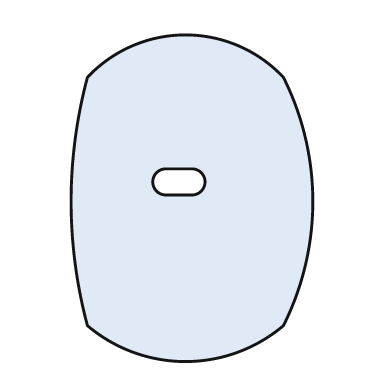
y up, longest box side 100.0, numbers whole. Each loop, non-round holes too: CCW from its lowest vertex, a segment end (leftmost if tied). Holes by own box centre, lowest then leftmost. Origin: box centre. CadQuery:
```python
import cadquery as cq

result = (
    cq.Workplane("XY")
    .moveTo(-32.0, -39.0)
    .threePointArc((-2.0, -50.0), (28.0, -39.0))
    .threePointArc((37.0, -1.0), (28.0, 37.0))
    .threePointArc((-2.0, 50.0), (-32.0, 37.0))
    .threePointArc((-37.0, -1.0), (-32.0, -39.0))
    .close()
    .moveTo(-8.0, 1.0)
    .lineTo(0.0, 1.0)
    .threePointArc((4.0, 5.0), (0.0, 9.0))
    .lineTo(-8.0, 9.0)
    .threePointArc((-12.0, 5.0), (-8.0, 1.0))
    .close()
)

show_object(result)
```